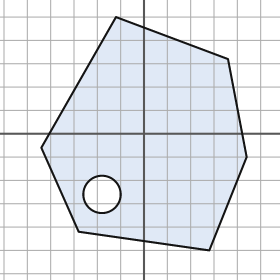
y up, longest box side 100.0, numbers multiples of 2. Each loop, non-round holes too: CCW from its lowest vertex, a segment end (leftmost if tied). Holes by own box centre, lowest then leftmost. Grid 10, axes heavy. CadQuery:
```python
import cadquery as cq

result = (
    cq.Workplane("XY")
    .moveTo(28.0, -50.0)
    .lineTo(44.0, -10.0)
    .lineTo(36.0, 32.0)
    .lineTo(-12.0, 50.0)
    .lineTo(-44.0, -6.0)
    .lineTo(-28.0, -42.0)
    .close()
    .moveTo(-18.0, -26.0)
    .circle(8.0)
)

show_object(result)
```